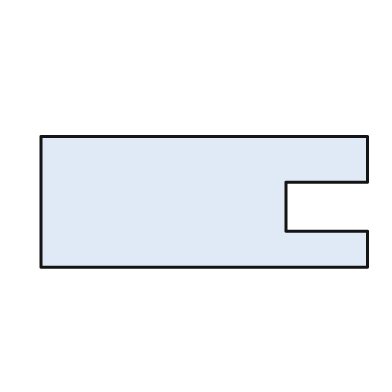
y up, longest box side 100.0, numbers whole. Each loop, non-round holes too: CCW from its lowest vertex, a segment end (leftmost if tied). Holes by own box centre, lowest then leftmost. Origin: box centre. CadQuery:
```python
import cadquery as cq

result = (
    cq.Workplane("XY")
    .moveTo(-50.0, -20.0)
    .lineTo(50.0, -20.0)
    .lineTo(50.0, -9.0)
    .lineTo(25.0, -9.0)
    .lineTo(25.0, 6.0)
    .lineTo(50.0, 6.0)
    .lineTo(50.0, 20.0)
    .lineTo(-50.0, 20.0)
    .close()
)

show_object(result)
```